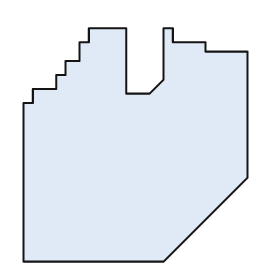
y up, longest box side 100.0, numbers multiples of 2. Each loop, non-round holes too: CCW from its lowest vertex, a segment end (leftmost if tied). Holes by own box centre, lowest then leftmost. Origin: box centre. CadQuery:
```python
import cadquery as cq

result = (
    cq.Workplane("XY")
    .moveTo(-48.0, -50.0)
    .lineTo(12.0, -50.0)
    .lineTo(48.0, -14.0)
    .lineTo(48.0, 40.0)
    .lineTo(30.0, 40.0)
    .lineTo(30.0, 44.0)
    .lineTo(16.0, 44.0)
    .lineTo(16.0, 50.0)
    .lineTo(12.0, 50.0)
    .lineTo(12.0, 28.0)
    .lineTo(6.0, 22.0)
    .lineTo(-4.0, 22.0)
    .lineTo(-4.0, 50.0)
    .lineTo(-20.0, 50.0)
    .lineTo(-20.0, 44.0)
    .lineTo(-24.0, 44.0)
    .lineTo(-24.0, 36.0)
    .lineTo(-30.0, 36.0)
    .lineTo(-30.0, 30.0)
    .lineTo(-34.0, 30.0)
    .lineTo(-34.0, 24.0)
    .lineTo(-44.0, 24.0)
    .lineTo(-44.0, 18.0)
    .lineTo(-48.0, 18.0)
    .close()
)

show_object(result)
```